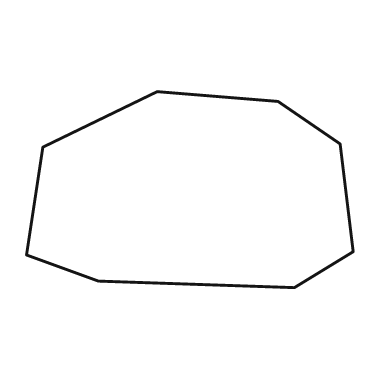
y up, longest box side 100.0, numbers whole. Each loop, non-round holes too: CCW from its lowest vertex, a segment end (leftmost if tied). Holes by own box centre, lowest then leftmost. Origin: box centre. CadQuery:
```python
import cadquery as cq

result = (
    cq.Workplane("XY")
    .moveTo(32.0, -30.0)
    .lineTo(50.0, -19.0)
    .lineTo(46.0, 14.0)
    .lineTo(27.0, 27.0)
    .lineTo(-10.0, 30.0)
    .lineTo(-45.0, 13.0)
    .lineTo(-50.0, -20.0)
    .lineTo(-28.0, -28.0)
    .close()
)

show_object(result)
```